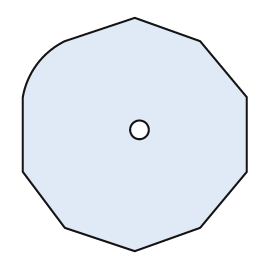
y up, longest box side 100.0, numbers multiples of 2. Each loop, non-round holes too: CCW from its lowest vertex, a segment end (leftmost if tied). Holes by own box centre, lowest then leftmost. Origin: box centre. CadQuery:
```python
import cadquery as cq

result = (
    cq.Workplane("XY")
    .moveTo(0.0, -50.0)
    .lineTo(28.0, -40.0)
    .lineTo(48.0, -16.0)
    .lineTo(48.0, 16.0)
    .lineTo(28.0, 40.0)
    .lineTo(0.0, 50.0)
    .lineTo(-30.0, 40.0)
    .threePointArc((-42.0, 30.0), (-48.0, 16.0))
    .lineTo(-48.0, -16.0)
    .lineTo(-30.0, -40.0)
    .close()
    .moveTo(2.0, 2.0)
    .circle(4.0)
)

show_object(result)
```